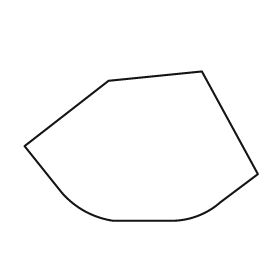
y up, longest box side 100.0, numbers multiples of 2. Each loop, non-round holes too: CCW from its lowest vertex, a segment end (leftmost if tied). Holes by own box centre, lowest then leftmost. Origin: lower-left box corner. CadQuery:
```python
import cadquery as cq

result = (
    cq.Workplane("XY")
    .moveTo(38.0, 0.0)
    .lineTo(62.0, 0.0)
    .threePointArc((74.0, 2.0), (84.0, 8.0))
    .lineTo(100.0, 20.0)
    .lineTo(76.0, 64.0)
    .lineTo(36.0, 60.0)
    .lineTo(0.0, 32.0)
    .lineTo(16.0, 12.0)
    .threePointArc((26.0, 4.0), (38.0, 0.0))
    .close()
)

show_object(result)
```